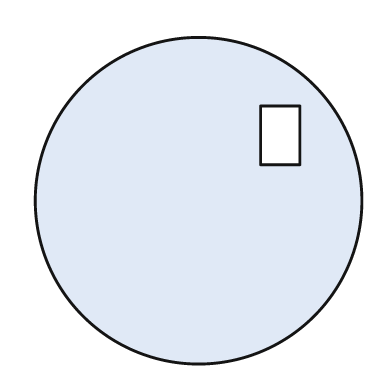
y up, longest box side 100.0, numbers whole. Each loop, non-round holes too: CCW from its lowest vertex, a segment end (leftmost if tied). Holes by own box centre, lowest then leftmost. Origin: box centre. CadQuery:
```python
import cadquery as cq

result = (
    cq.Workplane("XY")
    .moveTo(0.0, 0.0)
    .circle(50.0)
    .moveTo(19.0, 11.0)
    .lineTo(31.0, 11.0)
    .lineTo(31.0, 29.0)
    .lineTo(19.0, 29.0)
    .close()
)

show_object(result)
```